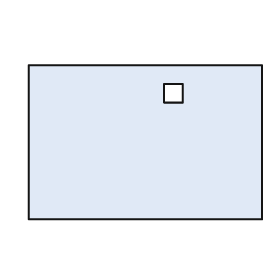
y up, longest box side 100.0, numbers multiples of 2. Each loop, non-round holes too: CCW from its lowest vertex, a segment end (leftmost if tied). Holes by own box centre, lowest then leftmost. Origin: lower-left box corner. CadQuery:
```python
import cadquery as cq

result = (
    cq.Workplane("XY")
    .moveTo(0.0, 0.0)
    .lineTo(100.0, 0.0)
    .lineTo(100.0, 66.0)
    .lineTo(0.0, 66.0)
    .close()
    .moveTo(58.0, 50.0)
    .lineTo(66.0, 50.0)
    .lineTo(66.0, 58.0)
    .lineTo(58.0, 58.0)
    .close()
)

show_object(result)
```